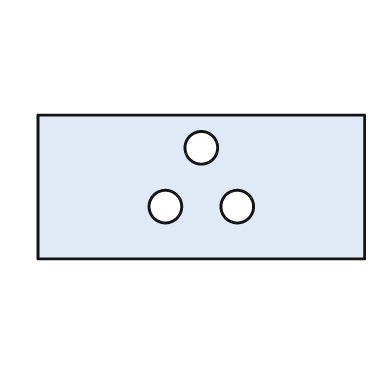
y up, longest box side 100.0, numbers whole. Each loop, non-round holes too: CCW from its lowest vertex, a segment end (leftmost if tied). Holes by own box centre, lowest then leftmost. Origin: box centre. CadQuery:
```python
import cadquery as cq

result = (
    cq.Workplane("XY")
    .moveTo(-50.0, -22.0)
    .lineTo(50.0, -22.0)
    .lineTo(50.0, 22.0)
    .lineTo(-50.0, 22.0)
    .close()
    .moveTo(-11.0, -6.0)
    .circle(5.0)
    .moveTo(11.0, -6.0)
    .circle(5.0)
    .moveTo(0.0, 12.0)
    .circle(5.0)
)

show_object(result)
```